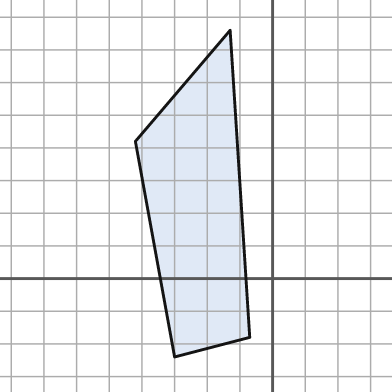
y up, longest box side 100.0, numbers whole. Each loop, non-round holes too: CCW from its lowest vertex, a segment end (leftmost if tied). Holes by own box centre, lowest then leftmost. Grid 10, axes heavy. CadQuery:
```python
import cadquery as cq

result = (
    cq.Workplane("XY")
    .moveTo(-30.0, -24.0)
    .lineTo(-7.0, -18.0)
    .lineTo(-13.0, 76.0)
    .lineTo(-42.0, 42.0)
    .close()
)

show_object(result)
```